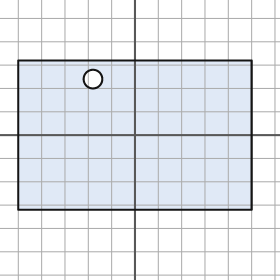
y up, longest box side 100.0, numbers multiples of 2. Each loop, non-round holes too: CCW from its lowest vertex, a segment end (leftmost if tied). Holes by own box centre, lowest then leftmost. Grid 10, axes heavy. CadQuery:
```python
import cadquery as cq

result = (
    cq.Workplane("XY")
    .moveTo(-50.0, -32.0)
    .lineTo(50.0, -32.0)
    .lineTo(50.0, 32.0)
    .lineTo(-50.0, 32.0)
    .close()
    .moveTo(-18.0, 24.0)
    .circle(4.0)
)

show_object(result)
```